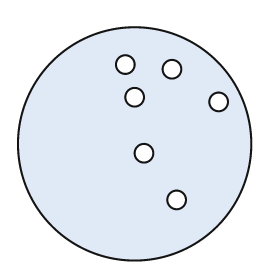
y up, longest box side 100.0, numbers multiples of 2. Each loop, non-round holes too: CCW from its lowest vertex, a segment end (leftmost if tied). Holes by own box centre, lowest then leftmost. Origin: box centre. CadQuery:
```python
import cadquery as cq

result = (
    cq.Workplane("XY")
    .moveTo(0.0, 0.0)
    .circle(50.0)
    .moveTo(18.0, -24.0)
    .circle(4.0)
    .moveTo(4.0, -4.0)
    .circle(4.0)
    .moveTo(36.0, 18.0)
    .circle(4.0)
    .moveTo(0.0, 20.0)
    .circle(4.0)
    .moveTo(16.0, 32.0)
    .circle(4.0)
    .moveTo(-4.0, 34.0)
    .circle(4.0)
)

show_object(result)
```